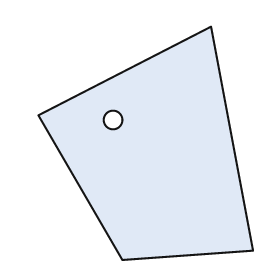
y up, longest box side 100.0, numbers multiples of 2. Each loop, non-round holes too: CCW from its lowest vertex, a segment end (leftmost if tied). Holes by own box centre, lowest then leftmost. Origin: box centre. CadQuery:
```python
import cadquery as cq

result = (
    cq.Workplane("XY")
    .moveTo(-10.0, -50.0)
    .lineTo(46.0, -46.0)
    .lineTo(28.0, 50.0)
    .lineTo(-46.0, 12.0)
    .close()
    .moveTo(-14.0, 10.0)
    .circle(4.0)
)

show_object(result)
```